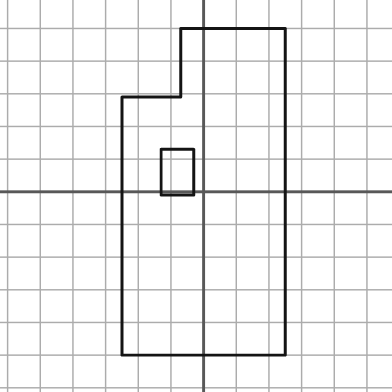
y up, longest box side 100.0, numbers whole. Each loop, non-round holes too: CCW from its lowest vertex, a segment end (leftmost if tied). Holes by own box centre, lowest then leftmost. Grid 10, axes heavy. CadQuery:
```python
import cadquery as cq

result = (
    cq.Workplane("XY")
    .moveTo(-25.0, -50.0)
    .lineTo(25.0, -50.0)
    .lineTo(25.0, 50.0)
    .lineTo(-7.0, 50.0)
    .lineTo(-7.0, 29.0)
    .lineTo(-25.0, 29.0)
    .close()
    .moveTo(-13.0, -1.0)
    .lineTo(-3.0, -1.0)
    .lineTo(-3.0, 13.0)
    .lineTo(-13.0, 13.0)
    .close()
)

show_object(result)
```